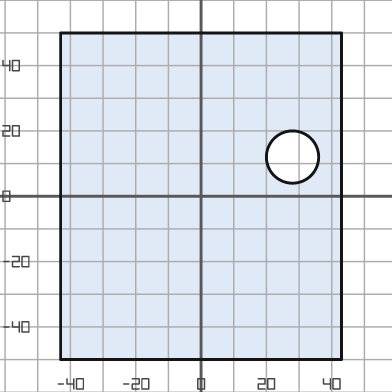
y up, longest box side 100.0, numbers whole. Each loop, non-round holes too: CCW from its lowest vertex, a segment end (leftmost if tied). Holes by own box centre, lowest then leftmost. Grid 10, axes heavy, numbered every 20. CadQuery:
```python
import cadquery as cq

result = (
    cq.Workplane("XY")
    .moveTo(-43.0, -50.0)
    .lineTo(43.0, -50.0)
    .lineTo(43.0, 50.0)
    .lineTo(-43.0, 50.0)
    .close()
    .moveTo(28.0, 12.0)
    .circle(8.0)
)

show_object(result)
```